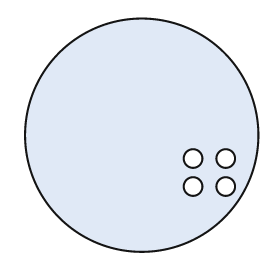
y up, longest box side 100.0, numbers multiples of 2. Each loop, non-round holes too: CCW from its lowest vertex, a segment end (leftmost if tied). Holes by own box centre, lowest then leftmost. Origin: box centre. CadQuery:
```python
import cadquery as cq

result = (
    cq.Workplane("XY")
    .moveTo(0.0, 0.0)
    .circle(50.0)
    .moveTo(22.0, -22.0)
    .circle(4.0)
    .moveTo(36.0, -22.0)
    .circle(4.0)
    .moveTo(22.0, -10.0)
    .circle(4.0)
    .moveTo(36.0, -10.0)
    .circle(4.0)
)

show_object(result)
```